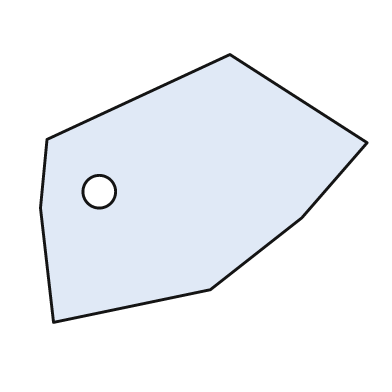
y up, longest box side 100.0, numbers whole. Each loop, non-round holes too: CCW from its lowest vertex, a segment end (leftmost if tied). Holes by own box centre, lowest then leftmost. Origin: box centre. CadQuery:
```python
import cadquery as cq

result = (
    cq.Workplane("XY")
    .moveTo(-46.0, -41.0)
    .lineTo(2.0, -31.0)
    .lineTo(30.0, -9.0)
    .lineTo(50.0, 14.0)
    .lineTo(8.0, 41.0)
    .lineTo(-48.0, 15.0)
    .lineTo(-50.0, -6.0)
    .close()
    .moveTo(-32.0, -1.0)
    .circle(5.0)
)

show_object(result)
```